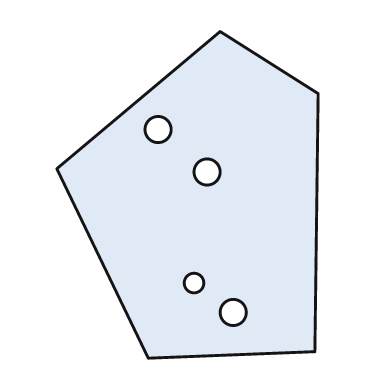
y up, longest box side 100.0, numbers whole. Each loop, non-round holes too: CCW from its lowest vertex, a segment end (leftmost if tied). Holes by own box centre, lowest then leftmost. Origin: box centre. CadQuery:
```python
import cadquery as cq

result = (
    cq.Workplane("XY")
    .moveTo(-12.0, -50.0)
    .lineTo(39.0, -48.0)
    .lineTo(40.0, 31.0)
    .lineTo(10.0, 50.0)
    .lineTo(-40.0, 8.0)
    .close()
    .moveTo(14.0, -36.0)
    .circle(4.0)
    .moveTo(2.0, -27.0)
    .circle(3.0)
    .moveTo(6.0, 7.0)
    .circle(4.0)
    .moveTo(-9.0, 20.0)
    .circle(4.0)
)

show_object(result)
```